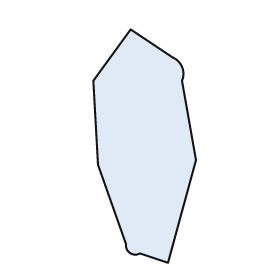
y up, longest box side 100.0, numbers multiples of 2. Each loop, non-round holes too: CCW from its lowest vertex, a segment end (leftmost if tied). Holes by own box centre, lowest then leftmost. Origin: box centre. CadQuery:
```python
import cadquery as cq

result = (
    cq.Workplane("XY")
    .moveTo(10.0, -50.0)
    .lineTo(22.0, -6.0)
    .lineTo(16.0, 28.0)
    .threePointArc((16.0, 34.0), (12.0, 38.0))
    .lineTo(-6.0, 50.0)
    .lineTo(-22.0, 28.0)
    .lineTo(-20.0, -8.0)
    .lineTo(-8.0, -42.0)
    .threePointArc((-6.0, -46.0), (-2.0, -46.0))
    .close()
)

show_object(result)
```